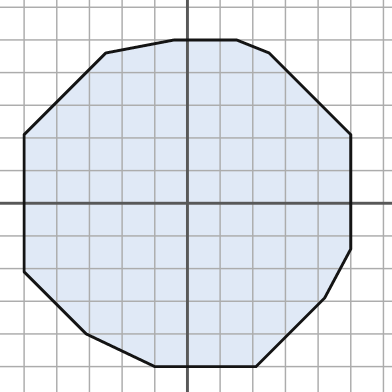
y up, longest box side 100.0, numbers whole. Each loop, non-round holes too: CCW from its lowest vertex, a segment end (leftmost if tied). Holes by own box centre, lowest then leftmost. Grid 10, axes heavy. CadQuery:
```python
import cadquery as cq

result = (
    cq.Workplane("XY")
    .moveTo(-10.0, -50.0)
    .lineTo(21.0, -50.0)
    .lineTo(42.0, -29.0)
    .lineTo(50.0, -14.0)
    .lineTo(50.0, 21.0)
    .lineTo(25.0, 46.0)
    .lineTo(15.0, 50.0)
    .lineTo(-4.0, 50.0)
    .lineTo(-25.0, 46.0)
    .lineTo(-50.0, 21.0)
    .lineTo(-50.0, -21.0)
    .lineTo(-31.0, -40.0)
    .close()
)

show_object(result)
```